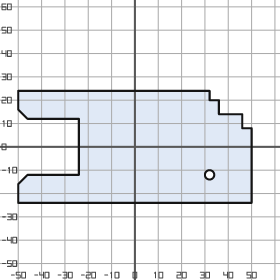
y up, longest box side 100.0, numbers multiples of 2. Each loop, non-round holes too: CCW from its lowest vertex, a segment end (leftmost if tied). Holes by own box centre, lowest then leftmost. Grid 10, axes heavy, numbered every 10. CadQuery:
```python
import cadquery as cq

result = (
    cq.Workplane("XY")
    .moveTo(-50.0, -24.0)
    .lineTo(50.0, -24.0)
    .lineTo(50.0, 8.0)
    .lineTo(46.0, 8.0)
    .lineTo(46.0, 14.0)
    .lineTo(36.0, 14.0)
    .lineTo(36.0, 20.0)
    .lineTo(32.0, 20.0)
    .lineTo(32.0, 24.0)
    .lineTo(-50.0, 24.0)
    .lineTo(-50.0, 16.0)
    .lineTo(-46.0, 12.0)
    .lineTo(-24.0, 12.0)
    .lineTo(-24.0, -12.0)
    .lineTo(-46.0, -12.0)
    .lineTo(-50.0, -16.0)
    .close()
    .moveTo(32.0, -12.0)
    .circle(2.0)
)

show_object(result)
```